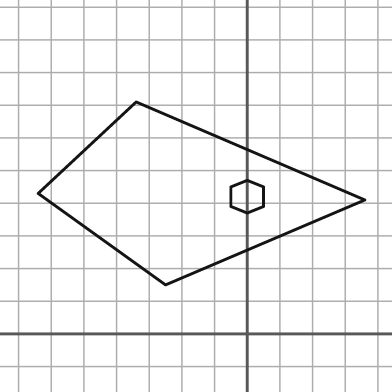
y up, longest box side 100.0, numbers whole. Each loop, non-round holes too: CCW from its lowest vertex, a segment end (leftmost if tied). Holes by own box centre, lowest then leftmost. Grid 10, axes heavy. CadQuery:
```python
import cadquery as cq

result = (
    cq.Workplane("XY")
    .moveTo(-25.0, 15.0)
    .lineTo(36.0, 41.0)
    .lineTo(-34.0, 71.0)
    .lineTo(-64.0, 43.0)
    .close()
    .moveTo(0.0, 37.0)
    .lineTo(5.0, 39.0)
    .lineTo(5.0, 45.0)
    .lineTo(0.0, 47.0)
    .lineTo(-5.0, 45.0)
    .lineTo(-5.0, 39.0)
    .close()
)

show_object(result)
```